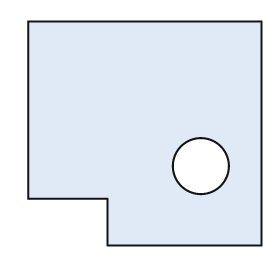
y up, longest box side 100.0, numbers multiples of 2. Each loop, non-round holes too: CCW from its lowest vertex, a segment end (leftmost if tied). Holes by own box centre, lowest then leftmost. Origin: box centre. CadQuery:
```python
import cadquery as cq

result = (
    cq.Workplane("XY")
    .moveTo(-16.0, -48.0)
    .lineTo(50.0, -48.0)
    .lineTo(50.0, 48.0)
    .lineTo(-50.0, 48.0)
    .lineTo(-50.0, -28.0)
    .lineTo(-16.0, -28.0)
    .close()
    .moveTo(24.0, -14.0)
    .circle(12.0)
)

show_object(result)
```